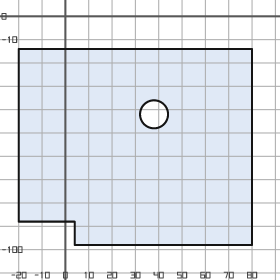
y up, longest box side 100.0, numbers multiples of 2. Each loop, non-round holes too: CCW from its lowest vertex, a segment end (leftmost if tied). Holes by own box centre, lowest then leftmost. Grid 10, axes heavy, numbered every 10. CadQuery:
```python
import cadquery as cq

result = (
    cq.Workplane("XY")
    .moveTo(4.0, -98.0)
    .lineTo(80.0, -98.0)
    .lineTo(80.0, -14.0)
    .lineTo(-20.0, -14.0)
    .lineTo(-20.0, -88.0)
    .lineTo(4.0, -88.0)
    .close()
    .moveTo(38.0, -42.0)
    .circle(6.0)
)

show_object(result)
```